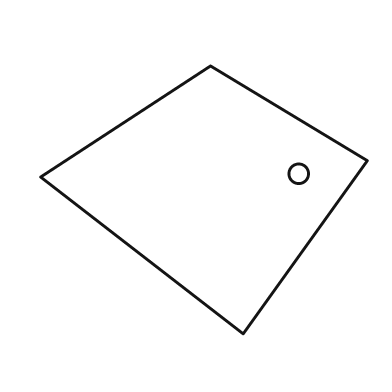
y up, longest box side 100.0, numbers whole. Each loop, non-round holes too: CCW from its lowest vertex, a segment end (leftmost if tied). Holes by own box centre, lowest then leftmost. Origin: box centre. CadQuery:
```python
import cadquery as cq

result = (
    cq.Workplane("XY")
    .moveTo(12.0, -41.0)
    .lineTo(50.0, 12.0)
    .lineTo(2.0, 41.0)
    .lineTo(-50.0, 7.0)
    .close()
    .moveTo(29.0, 8.0)
    .circle(3.0)
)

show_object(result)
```